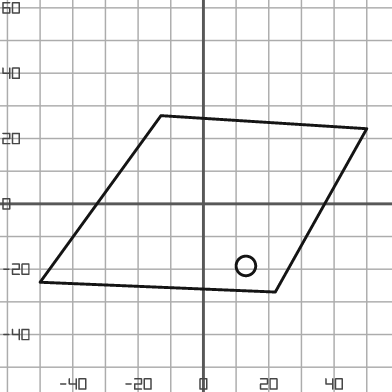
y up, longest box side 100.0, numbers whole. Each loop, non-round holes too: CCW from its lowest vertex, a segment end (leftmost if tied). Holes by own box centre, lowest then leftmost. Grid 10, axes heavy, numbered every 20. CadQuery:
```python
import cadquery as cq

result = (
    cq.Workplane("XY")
    .moveTo(22.0, -27.0)
    .lineTo(50.0, 23.0)
    .lineTo(-13.0, 27.0)
    .lineTo(-50.0, -24.0)
    .close()
    .moveTo(13.0, -19.0)
    .circle(3.0)
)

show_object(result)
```